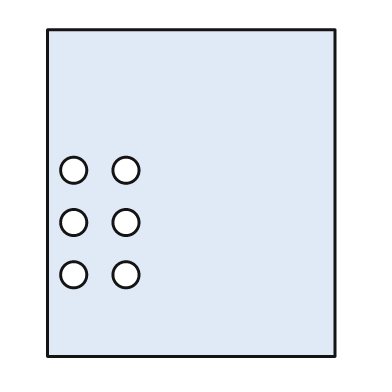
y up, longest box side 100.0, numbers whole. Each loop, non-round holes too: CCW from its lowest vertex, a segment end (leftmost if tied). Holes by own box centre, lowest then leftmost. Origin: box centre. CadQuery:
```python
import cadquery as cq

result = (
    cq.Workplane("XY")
    .moveTo(-44.0, -50.0)
    .lineTo(44.0, -50.0)
    .lineTo(44.0, 50.0)
    .lineTo(-44.0, 50.0)
    .close()
    .moveTo(-36.0, -25.0)
    .circle(4.0)
    .moveTo(-20.0, -25.0)
    .circle(4.0)
    .moveTo(-36.0, -9.0)
    .circle(4.0)
    .moveTo(-20.0, -9.0)
    .circle(4.0)
    .moveTo(-36.0, 7.0)
    .circle(4.0)
    .moveTo(-20.0, 7.0)
    .circle(4.0)
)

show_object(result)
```